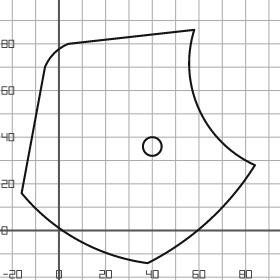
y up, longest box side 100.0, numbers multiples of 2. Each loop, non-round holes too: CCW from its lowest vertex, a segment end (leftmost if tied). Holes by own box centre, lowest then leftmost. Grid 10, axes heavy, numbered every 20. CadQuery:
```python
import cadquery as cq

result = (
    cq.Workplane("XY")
    .moveTo(38.0, -14.0)
    .threePointArc((64.0, 4.0), (84.0, 28.0))
    .threePointArc((60.0, 52.0), (58.0, 86.0))
    .lineTo(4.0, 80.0)
    .threePointArc((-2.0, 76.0), (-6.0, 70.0))
    .lineTo(-16.0, 16.0)
    .threePointArc((8.0, -4.0), (38.0, -14.0))
    .close()
    .moveTo(40.0, 36.0)
    .circle(4.0)
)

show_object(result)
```